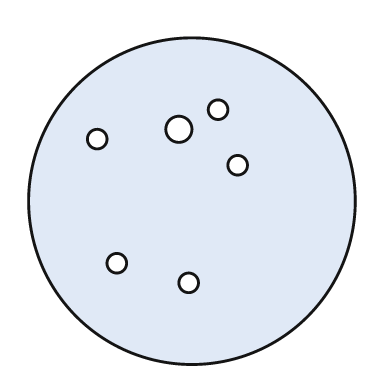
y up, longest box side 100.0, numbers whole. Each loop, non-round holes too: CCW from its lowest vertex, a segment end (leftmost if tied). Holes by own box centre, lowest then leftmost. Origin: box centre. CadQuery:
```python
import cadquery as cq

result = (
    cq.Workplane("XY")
    .moveTo(0.0, 0.0)
    .circle(50.0)
    .moveTo(-1.0, -25.0)
    .circle(3.0)
    .moveTo(-23.0, -19.0)
    .circle(3.0)
    .moveTo(14.0, 11.0)
    .circle(3.0)
    .moveTo(-29.0, 19.0)
    .circle(3.0)
    .moveTo(-4.0, 22.0)
    .circle(4.0)
    .moveTo(8.0, 28.0)
    .circle(3.0)
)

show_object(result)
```